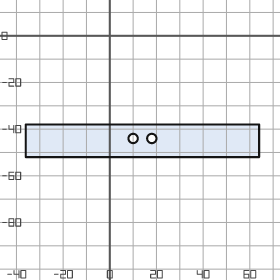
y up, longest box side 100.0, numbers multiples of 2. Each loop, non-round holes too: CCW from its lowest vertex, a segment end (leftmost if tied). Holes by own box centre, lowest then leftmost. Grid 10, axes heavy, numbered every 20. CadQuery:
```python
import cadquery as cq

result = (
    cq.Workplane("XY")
    .moveTo(-36.0, -52.0)
    .lineTo(64.0, -52.0)
    .lineTo(64.0, -38.0)
    .lineTo(-36.0, -38.0)
    .close()
    .moveTo(10.0, -44.0)
    .circle(2.0)
    .moveTo(18.0, -44.0)
    .circle(2.0)
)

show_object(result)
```